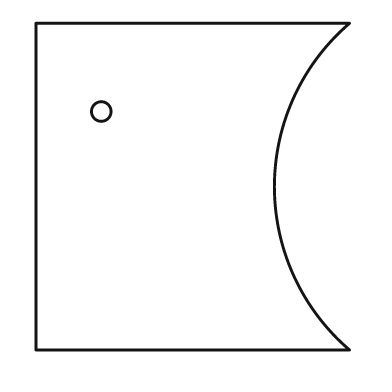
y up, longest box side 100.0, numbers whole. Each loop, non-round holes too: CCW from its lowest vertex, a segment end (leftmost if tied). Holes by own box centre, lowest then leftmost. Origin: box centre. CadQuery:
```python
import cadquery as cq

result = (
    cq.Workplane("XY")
    .moveTo(-48.0, -50.0)
    .lineTo(48.0, -50.0)
    .threePointArc((25.0, 0.0), (48.0, 50.0))
    .lineTo(-48.0, 50.0)
    .close()
    .moveTo(-28.0, 23.0)
    .circle(3.0)
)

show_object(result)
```